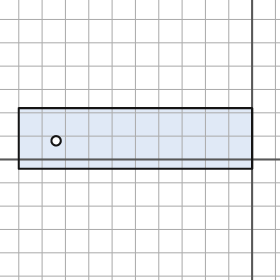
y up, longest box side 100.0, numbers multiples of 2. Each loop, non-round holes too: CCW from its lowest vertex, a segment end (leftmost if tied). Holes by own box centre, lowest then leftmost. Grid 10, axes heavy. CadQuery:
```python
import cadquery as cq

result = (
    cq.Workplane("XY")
    .moveTo(-100.0, -4.0)
    .lineTo(0.0, -4.0)
    .lineTo(0.0, 22.0)
    .lineTo(-100.0, 22.0)
    .close()
    .moveTo(-84.0, 8.0)
    .circle(2.0)
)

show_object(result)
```